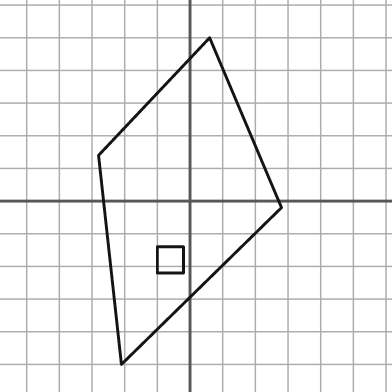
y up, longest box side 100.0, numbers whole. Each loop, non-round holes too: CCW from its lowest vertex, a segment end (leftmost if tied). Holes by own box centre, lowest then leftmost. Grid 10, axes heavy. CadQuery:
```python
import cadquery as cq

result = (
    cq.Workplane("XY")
    .moveTo(-21.0, -50.0)
    .lineTo(28.0, -2.0)
    .lineTo(6.0, 50.0)
    .lineTo(-28.0, 14.0)
    .close()
    .moveTo(-10.0, -22.0)
    .lineTo(-2.0, -22.0)
    .lineTo(-2.0, -14.0)
    .lineTo(-10.0, -14.0)
    .close()
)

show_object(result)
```